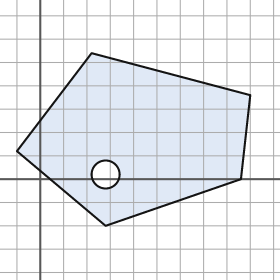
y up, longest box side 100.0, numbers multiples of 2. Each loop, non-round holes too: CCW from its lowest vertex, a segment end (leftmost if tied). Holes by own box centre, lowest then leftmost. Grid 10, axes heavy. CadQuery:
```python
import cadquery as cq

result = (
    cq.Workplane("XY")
    .moveTo(28.0, -20.0)
    .lineTo(86.0, 0.0)
    .lineTo(90.0, 36.0)
    .lineTo(22.0, 54.0)
    .lineTo(-10.0, 12.0)
    .close()
    .moveTo(28.0, 2.0)
    .circle(6.0)
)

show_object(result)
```